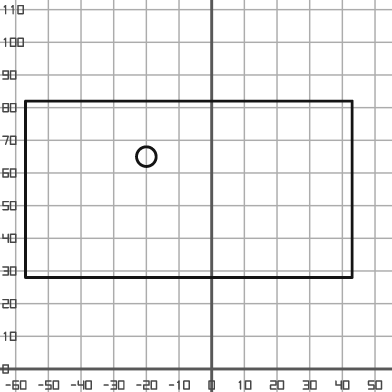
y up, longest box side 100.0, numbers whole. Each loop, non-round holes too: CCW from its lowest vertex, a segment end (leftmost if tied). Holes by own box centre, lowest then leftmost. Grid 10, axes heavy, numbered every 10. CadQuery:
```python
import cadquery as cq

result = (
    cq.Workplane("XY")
    .moveTo(-57.0, 28.0)
    .lineTo(43.0, 28.0)
    .lineTo(43.0, 82.0)
    .lineTo(-57.0, 82.0)
    .close()
    .moveTo(-20.0, 65.0)
    .circle(3.0)
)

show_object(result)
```